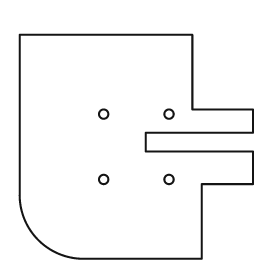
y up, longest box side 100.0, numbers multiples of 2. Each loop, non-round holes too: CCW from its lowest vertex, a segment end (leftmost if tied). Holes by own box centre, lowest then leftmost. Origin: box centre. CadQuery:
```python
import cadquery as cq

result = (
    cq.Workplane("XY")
    .moveTo(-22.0, -48.0)
    .lineTo(28.0, -48.0)
    .lineTo(28.0, -16.0)
    .lineTo(50.0, -16.0)
    .lineTo(50.0, -2.0)
    .lineTo(4.0, -2.0)
    .lineTo(4.0, 6.0)
    .lineTo(50.0, 6.0)
    .lineTo(50.0, 16.0)
    .lineTo(24.0, 16.0)
    .lineTo(24.0, 48.0)
    .lineTo(-50.0, 48.0)
    .lineTo(-50.0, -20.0)
    .threePointArc((-42.0, -40.0), (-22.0, -48.0))
    .close()
    .moveTo(-14.0, -14.0)
    .circle(2.0)
    .moveTo(14.0, -14.0)
    .circle(2.0)
    .moveTo(-14.0, 14.0)
    .circle(2.0)
    .moveTo(14.0, 14.0)
    .circle(2.0)
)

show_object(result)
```